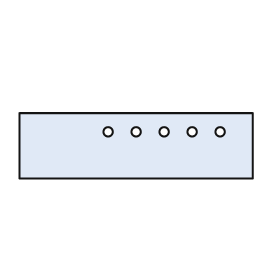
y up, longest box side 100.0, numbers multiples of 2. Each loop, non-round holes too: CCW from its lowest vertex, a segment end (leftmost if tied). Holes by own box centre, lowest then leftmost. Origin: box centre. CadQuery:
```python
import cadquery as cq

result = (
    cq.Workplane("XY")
    .moveTo(-50.0, -14.0)
    .lineTo(50.0, -14.0)
    .lineTo(50.0, 14.0)
    .lineTo(-50.0, 14.0)
    .close()
    .moveTo(-12.0, 6.0)
    .circle(2.0)
    .moveTo(0.0, 6.0)
    .circle(2.0)
    .moveTo(12.0, 6.0)
    .circle(2.0)
    .moveTo(24.0, 6.0)
    .circle(2.0)
    .moveTo(36.0, 6.0)
    .circle(2.0)
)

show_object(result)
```